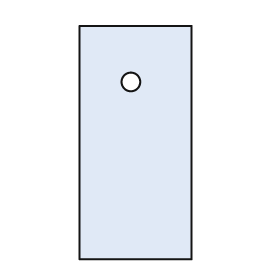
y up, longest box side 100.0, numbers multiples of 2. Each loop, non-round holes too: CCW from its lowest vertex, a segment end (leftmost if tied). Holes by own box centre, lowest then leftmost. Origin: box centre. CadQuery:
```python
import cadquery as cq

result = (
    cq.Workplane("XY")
    .moveTo(-24.0, -50.0)
    .lineTo(24.0, -50.0)
    .lineTo(24.0, 50.0)
    .lineTo(-24.0, 50.0)
    .close()
    .moveTo(-2.0, 26.0)
    .circle(4.0)
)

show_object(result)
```